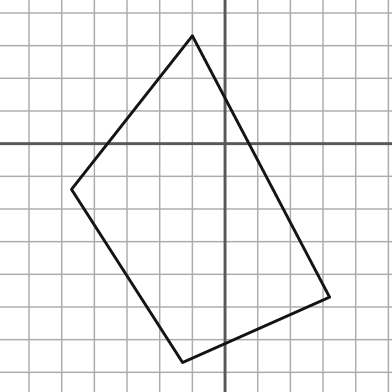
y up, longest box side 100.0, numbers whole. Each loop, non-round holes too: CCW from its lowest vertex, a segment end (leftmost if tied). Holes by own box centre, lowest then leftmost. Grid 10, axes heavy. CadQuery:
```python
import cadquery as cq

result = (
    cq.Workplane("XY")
    .moveTo(-13.0, -67.0)
    .lineTo(32.0, -47.0)
    .lineTo(-10.0, 33.0)
    .lineTo(-47.0, -14.0)
    .close()
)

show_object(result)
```